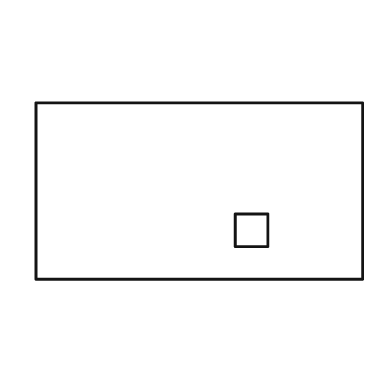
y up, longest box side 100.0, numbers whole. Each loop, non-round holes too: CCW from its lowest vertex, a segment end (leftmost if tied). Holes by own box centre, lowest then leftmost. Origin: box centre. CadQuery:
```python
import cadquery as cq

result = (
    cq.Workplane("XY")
    .moveTo(-50.0, -27.0)
    .lineTo(50.0, -27.0)
    .lineTo(50.0, 27.0)
    .lineTo(-50.0, 27.0)
    .close()
    .moveTo(11.0, -17.0)
    .lineTo(21.0, -17.0)
    .lineTo(21.0, -7.0)
    .lineTo(11.0, -7.0)
    .close()
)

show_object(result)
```